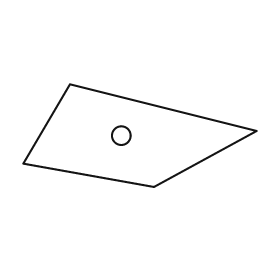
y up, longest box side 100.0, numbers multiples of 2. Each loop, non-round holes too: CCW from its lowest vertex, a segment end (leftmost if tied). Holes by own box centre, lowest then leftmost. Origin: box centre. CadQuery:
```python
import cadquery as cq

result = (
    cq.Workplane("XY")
    .moveTo(6.0, -22.0)
    .lineTo(50.0, 2.0)
    .lineTo(-30.0, 22.0)
    .lineTo(-50.0, -12.0)
    .close()
    .moveTo(-8.0, 0.0)
    .circle(4.0)
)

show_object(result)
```